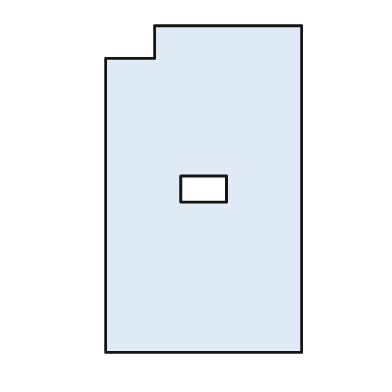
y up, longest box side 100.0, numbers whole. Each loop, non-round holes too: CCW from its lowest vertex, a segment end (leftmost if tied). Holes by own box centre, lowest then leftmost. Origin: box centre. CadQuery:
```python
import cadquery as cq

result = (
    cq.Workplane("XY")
    .moveTo(-30.0, -50.0)
    .lineTo(30.0, -50.0)
    .lineTo(30.0, 50.0)
    .lineTo(-15.0, 50.0)
    .lineTo(-15.0, 40.0)
    .lineTo(-30.0, 40.0)
    .close()
    .moveTo(-7.0, -4.0)
    .lineTo(7.0, -4.0)
    .lineTo(7.0, 4.0)
    .lineTo(-7.0, 4.0)
    .close()
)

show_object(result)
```